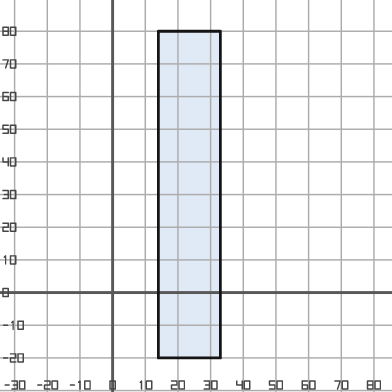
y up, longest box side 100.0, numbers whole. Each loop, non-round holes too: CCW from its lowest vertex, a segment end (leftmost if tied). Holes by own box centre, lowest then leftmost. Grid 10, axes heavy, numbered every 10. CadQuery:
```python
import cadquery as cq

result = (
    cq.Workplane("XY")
    .moveTo(14.0, -20.0)
    .lineTo(33.0, -20.0)
    .lineTo(33.0, 80.0)
    .lineTo(14.0, 80.0)
    .close()
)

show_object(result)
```